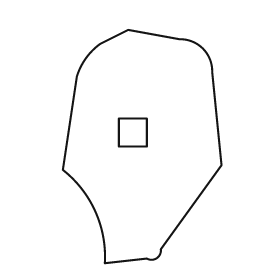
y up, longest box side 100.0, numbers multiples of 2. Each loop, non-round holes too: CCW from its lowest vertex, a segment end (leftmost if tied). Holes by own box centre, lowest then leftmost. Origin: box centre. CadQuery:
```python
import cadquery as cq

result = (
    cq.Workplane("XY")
    .moveTo(-16.0, -50.0)
    .lineTo(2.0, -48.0)
    .threePointArc((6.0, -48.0), (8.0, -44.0))
    .lineTo(34.0, -8.0)
    .lineTo(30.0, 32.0)
    .threePointArc((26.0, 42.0), (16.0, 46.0))
    .lineTo(-6.0, 50.0)
    .lineTo(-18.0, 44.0)
    .threePointArc((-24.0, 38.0), (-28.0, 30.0))
    .lineTo(-34.0, -10.0)
    .threePointArc((-20.0, -28.0), (-16.0, -50.0))
    .close()
    .moveTo(-10.0, 0.0)
    .lineTo(2.0, 0.0)
    .lineTo(2.0, 12.0)
    .lineTo(-10.0, 12.0)
    .close()
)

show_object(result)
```